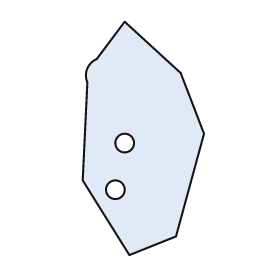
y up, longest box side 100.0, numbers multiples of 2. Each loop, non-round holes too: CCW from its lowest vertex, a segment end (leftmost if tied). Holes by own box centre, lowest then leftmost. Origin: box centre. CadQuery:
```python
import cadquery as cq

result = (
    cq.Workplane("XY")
    .moveTo(-6.0, -50.0)
    .lineTo(14.0, -42.0)
    .lineTo(26.0, 2.0)
    .lineTo(16.0, 28.0)
    .lineTo(-8.0, 50.0)
    .lineTo(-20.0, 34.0)
    .threePointArc((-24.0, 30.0), (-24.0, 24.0))
    .lineTo(-26.0, -18.0)
    .close()
    .moveTo(-12.0, -22.0)
    .circle(4.0)
    .moveTo(-8.0, -2.0)
    .circle(4.0)
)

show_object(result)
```